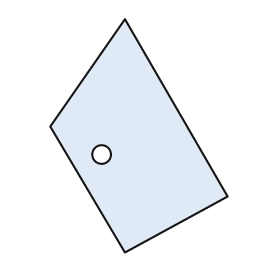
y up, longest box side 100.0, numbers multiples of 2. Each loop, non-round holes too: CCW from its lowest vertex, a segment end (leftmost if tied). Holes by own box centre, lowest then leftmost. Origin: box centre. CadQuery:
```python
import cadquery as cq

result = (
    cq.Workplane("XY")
    .moveTo(-6.0, -50.0)
    .lineTo(38.0, -26.0)
    .lineTo(-6.0, 50.0)
    .lineTo(-38.0, 4.0)
    .close()
    .moveTo(-16.0, -8.0)
    .circle(4.0)
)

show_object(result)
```